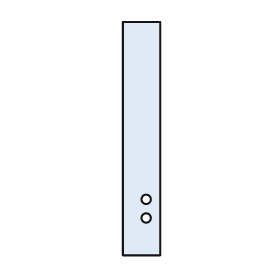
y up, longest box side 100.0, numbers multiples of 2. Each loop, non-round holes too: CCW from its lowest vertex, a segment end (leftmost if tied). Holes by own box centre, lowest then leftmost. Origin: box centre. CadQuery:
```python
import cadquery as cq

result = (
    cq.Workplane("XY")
    .moveTo(-8.0, -50.0)
    .lineTo(8.0, -50.0)
    .lineTo(8.0, 50.0)
    .lineTo(-8.0, 50.0)
    .close()
    .moveTo(2.0, -34.0)
    .circle(2.0)
    .moveTo(2.0, -26.0)
    .circle(2.0)
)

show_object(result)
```